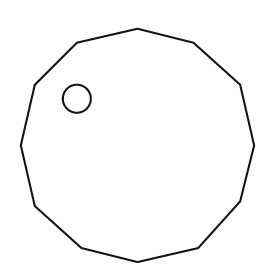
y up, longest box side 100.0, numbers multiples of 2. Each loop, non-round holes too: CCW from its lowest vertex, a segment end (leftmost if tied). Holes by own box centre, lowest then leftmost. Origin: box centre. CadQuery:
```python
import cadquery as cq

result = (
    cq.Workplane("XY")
    .moveTo(0.0, -50.0)
    .lineTo(26.0, -44.0)
    .lineTo(44.0, -24.0)
    .lineTo(50.0, 0.0)
    .lineTo(44.0, 26.0)
    .lineTo(24.0, 44.0)
    .lineTo(0.0, 50.0)
    .lineTo(-26.0, 44.0)
    .lineTo(-44.0, 26.0)
    .lineTo(-50.0, 0.0)
    .lineTo(-44.0, -26.0)
    .lineTo(-24.0, -44.0)
    .close()
    .moveTo(-26.0, 20.0)
    .circle(6.0)
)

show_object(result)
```